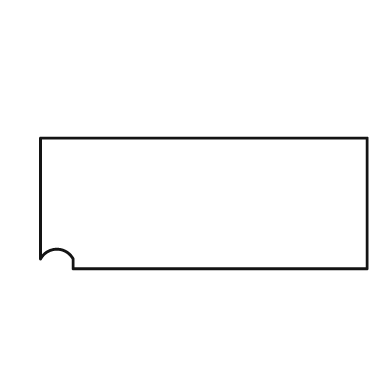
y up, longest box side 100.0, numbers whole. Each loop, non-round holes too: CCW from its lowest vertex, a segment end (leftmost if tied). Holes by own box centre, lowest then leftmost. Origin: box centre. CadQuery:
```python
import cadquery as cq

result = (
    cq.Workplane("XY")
    .moveTo(-40.0, -20.0)
    .lineTo(50.0, -20.0)
    .lineTo(50.0, 20.0)
    .lineTo(-50.0, 20.0)
    .lineTo(-50.0, -17.0)
    .threePointArc((-45.0, -14.0), (-40.0, -17.0))
    .close()
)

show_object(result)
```